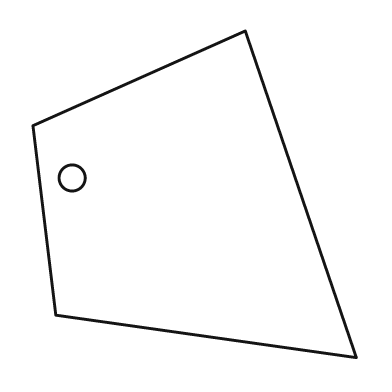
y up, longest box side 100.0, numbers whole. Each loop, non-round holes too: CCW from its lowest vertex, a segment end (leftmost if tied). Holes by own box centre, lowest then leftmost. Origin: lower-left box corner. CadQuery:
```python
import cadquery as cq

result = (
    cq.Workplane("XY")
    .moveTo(99.0, 0.0)
    .lineTo(65.0, 100.0)
    .lineTo(0.0, 71.0)
    .lineTo(7.0, 13.0)
    .close()
    .moveTo(12.0, 55.0)
    .circle(4.0)
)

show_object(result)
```